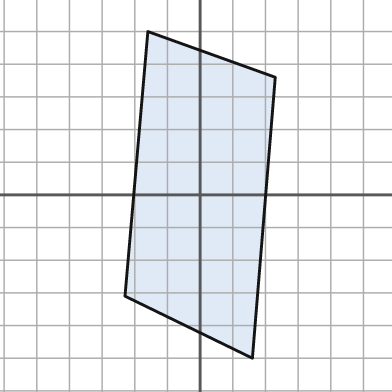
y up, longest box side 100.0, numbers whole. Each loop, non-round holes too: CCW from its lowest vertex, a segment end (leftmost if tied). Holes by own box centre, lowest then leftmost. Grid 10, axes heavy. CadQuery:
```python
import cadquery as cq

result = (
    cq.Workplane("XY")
    .moveTo(16.0, -50.0)
    .lineTo(23.0, 36.0)
    .lineTo(-16.0, 50.0)
    .lineTo(-23.0, -31.0)
    .close()
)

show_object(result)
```